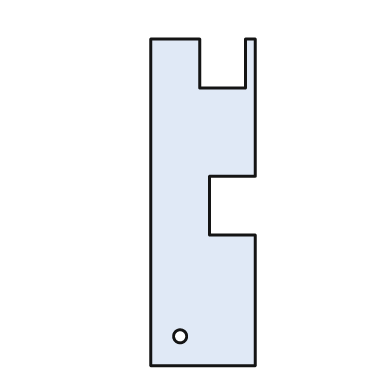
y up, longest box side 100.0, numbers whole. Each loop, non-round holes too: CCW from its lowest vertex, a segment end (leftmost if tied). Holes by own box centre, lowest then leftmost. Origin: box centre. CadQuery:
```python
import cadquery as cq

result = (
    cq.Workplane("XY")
    .moveTo(-16.0, -50.0)
    .lineTo(16.0, -50.0)
    .lineTo(16.0, -10.0)
    .lineTo(2.0, -10.0)
    .lineTo(2.0, 8.0)
    .lineTo(16.0, 8.0)
    .lineTo(16.0, 50.0)
    .lineTo(13.0, 50.0)
    .lineTo(13.0, 35.0)
    .lineTo(-1.0, 35.0)
    .lineTo(-1.0, 50.0)
    .lineTo(-16.0, 50.0)
    .close()
    .moveTo(-7.0, -41.0)
    .circle(2.0)
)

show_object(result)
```